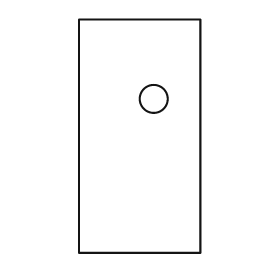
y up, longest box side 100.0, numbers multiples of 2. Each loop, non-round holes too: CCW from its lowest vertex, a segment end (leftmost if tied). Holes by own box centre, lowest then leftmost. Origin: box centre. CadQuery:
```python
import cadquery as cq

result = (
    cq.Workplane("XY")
    .moveTo(-26.0, -50.0)
    .lineTo(26.0, -50.0)
    .lineTo(26.0, 50.0)
    .lineTo(-26.0, 50.0)
    .close()
    .moveTo(6.0, 16.0)
    .circle(6.0)
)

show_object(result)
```